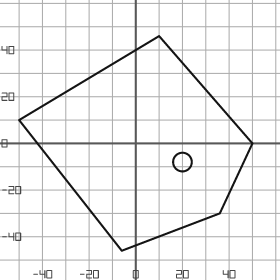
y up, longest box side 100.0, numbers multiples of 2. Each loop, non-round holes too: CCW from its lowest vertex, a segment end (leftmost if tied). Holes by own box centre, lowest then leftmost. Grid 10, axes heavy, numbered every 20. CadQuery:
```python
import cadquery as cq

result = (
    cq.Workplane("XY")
    .moveTo(-6.0, -46.0)
    .lineTo(36.0, -30.0)
    .lineTo(50.0, 0.0)
    .lineTo(10.0, 46.0)
    .lineTo(-50.0, 10.0)
    .close()
    .moveTo(20.0, -8.0)
    .circle(4.0)
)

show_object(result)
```